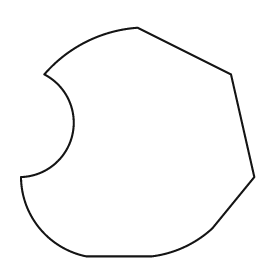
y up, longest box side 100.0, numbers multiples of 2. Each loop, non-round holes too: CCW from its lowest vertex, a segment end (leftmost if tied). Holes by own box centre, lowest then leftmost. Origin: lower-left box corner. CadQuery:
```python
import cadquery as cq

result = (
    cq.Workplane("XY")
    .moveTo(28.0, 0.0)
    .lineTo(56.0, 0.0)
    .threePointArc((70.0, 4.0), (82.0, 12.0))
    .lineTo(100.0, 34.0)
    .lineTo(90.0, 78.0)
    .lineTo(50.0, 98.0)
    .threePointArc((28.0, 92.0), (10.0, 78.0))
    .threePointArc((22.0, 52.0), (0.0, 34.0))
    .threePointArc((8.0, 12.0), (28.0, 0.0))
    .close()
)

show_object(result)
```